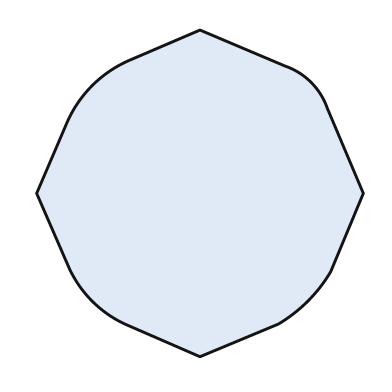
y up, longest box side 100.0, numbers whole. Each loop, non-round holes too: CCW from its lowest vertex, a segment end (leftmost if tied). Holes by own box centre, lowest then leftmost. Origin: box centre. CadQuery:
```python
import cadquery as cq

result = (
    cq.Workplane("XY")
    .moveTo(0.0, -50.0)
    .lineTo(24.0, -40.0)
    .threePointArc((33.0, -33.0), (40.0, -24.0))
    .lineTo(50.0, 0.0)
    .lineTo(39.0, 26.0)
    .threePointArc((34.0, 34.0), (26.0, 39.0))
    .lineTo(0.0, 50.0)
    .lineTo(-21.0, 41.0)
    .threePointArc((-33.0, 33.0), (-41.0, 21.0))
    .lineTo(-50.0, 0.0)
    .lineTo(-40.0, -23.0)
    .threePointArc((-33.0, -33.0), (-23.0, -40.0))
    .close()
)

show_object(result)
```